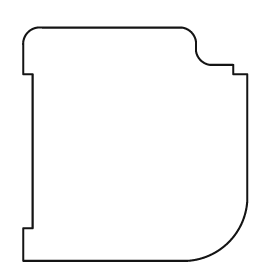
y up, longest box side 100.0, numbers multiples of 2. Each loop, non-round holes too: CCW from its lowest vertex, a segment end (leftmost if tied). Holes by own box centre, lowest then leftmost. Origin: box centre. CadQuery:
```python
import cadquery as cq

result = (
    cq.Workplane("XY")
    .moveTo(-48.0, -50.0)
    .lineTo(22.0, -50.0)
    .threePointArc((40.0, -42.0), (48.0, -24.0))
    .lineTo(48.0, 30.0)
    .lineTo(42.0, 30.0)
    .lineTo(42.0, 34.0)
    .lineTo(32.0, 34.0)
    .threePointArc((28.0, 36.0), (26.0, 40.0))
    .lineTo(26.0, 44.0)
    .threePointArc((24.0, 48.0), (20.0, 50.0))
    .lineTo(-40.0, 50.0)
    .threePointArc((-46.0, 48.0), (-48.0, 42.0))
    .lineTo(-48.0, 30.0)
    .lineTo(-44.0, 30.0)
    .lineTo(-44.0, -36.0)
    .lineTo(-48.0, -36.0)
    .close()
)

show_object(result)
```